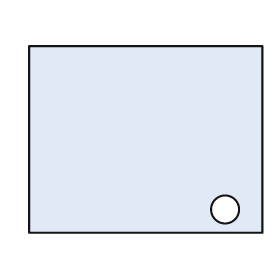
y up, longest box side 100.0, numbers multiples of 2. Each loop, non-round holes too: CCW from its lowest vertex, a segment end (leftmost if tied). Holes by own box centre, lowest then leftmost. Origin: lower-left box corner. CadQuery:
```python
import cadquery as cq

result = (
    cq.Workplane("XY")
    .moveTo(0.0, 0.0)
    .lineTo(100.0, 0.0)
    .lineTo(100.0, 80.0)
    .lineTo(0.0, 80.0)
    .close()
    .moveTo(84.0, 10.0)
    .circle(6.0)
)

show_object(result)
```